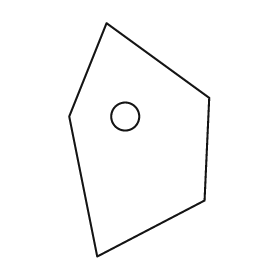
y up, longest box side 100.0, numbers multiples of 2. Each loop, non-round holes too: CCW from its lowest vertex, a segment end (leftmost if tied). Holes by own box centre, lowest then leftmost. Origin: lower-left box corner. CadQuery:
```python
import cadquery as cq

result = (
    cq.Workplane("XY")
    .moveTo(12.0, 0.0)
    .lineTo(58.0, 24.0)
    .lineTo(60.0, 68.0)
    .lineTo(16.0, 100.0)
    .lineTo(0.0, 60.0)
    .close()
    .moveTo(24.0, 60.0)
    .circle(6.0)
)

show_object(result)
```